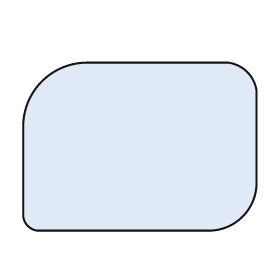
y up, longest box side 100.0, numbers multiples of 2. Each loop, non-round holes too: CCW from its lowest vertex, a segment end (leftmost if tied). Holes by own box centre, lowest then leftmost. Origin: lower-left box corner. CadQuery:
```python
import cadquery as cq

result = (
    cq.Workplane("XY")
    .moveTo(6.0, 0.0)
    .lineTo(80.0, 0.0)
    .threePointArc((94.0, 6.0), (100.0, 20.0))
    .lineTo(100.0, 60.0)
    .threePointArc((96.0, 68.0), (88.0, 72.0))
    .lineTo(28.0, 72.0)
    .threePointArc((8.0, 64.0), (0.0, 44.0))
    .lineTo(0.0, 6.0)
    .threePointArc((2.0, 2.0), (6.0, 0.0))
    .close()
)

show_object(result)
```